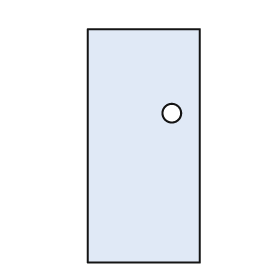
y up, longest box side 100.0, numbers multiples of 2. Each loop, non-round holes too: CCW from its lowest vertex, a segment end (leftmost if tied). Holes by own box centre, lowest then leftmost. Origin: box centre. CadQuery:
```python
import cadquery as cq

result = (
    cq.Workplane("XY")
    .moveTo(-24.0, -50.0)
    .lineTo(24.0, -50.0)
    .lineTo(24.0, 50.0)
    .lineTo(-24.0, 50.0)
    .close()
    .moveTo(12.0, 14.0)
    .circle(4.0)
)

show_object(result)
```